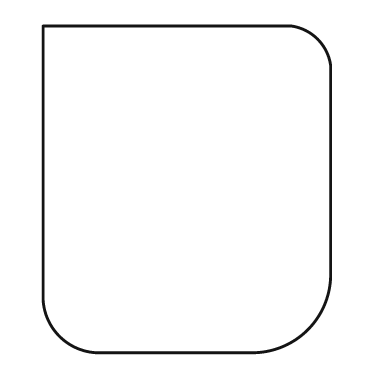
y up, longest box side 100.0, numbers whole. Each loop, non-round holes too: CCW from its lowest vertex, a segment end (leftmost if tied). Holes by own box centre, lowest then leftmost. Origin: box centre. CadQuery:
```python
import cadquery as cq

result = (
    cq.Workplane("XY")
    .moveTo(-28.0, -50.0)
    .lineTo(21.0, -50.0)
    .threePointArc((37.0, -43.0), (44.0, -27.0))
    .lineTo(44.0, 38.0)
    .threePointArc((40.0, 46.0), (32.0, 50.0))
    .lineTo(-44.0, 50.0)
    .lineTo(-44.0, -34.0)
    .threePointArc((-39.0, -45.0), (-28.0, -50.0))
    .close()
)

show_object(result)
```